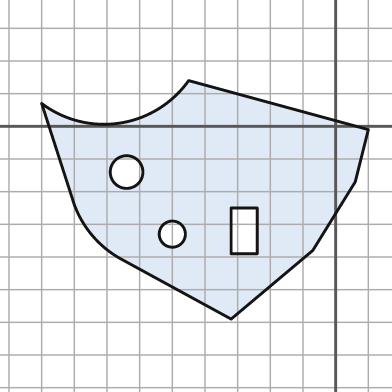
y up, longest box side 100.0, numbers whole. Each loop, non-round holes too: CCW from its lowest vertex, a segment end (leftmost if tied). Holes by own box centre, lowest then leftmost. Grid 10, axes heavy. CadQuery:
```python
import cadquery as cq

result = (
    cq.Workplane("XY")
    .moveTo(-32.0, -59.0)
    .lineTo(-7.0, -38.0)
    .lineTo(6.0, -17.0)
    .lineTo(10.0, -1.0)
    .lineTo(-45.0, 14.0)
    .threePointArc((-66.0, 1.0), (-90.0, 7.0))
    .lineTo(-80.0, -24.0)
    .threePointArc((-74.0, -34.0), (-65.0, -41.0))
    .close()
    .moveTo(-50.0, -33.0)
    .circle(4.0)
    .moveTo(-32.0, -39.0)
    .lineTo(-24.0, -39.0)
    .lineTo(-24.0, -25.0)
    .lineTo(-32.0, -25.0)
    .close()
    .moveTo(-64.0, -14.0)
    .circle(5.0)
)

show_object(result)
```